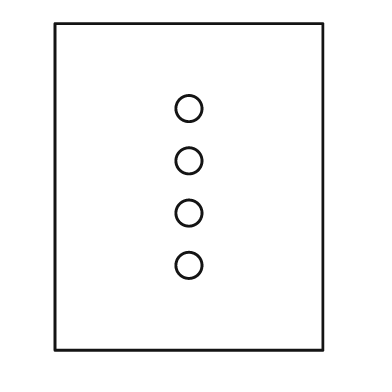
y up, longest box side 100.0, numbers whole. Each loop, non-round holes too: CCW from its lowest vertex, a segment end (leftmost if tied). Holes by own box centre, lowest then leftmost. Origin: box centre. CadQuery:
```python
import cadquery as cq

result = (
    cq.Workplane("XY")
    .moveTo(-41.0, -50.0)
    .lineTo(41.0, -50.0)
    .lineTo(41.0, 50.0)
    .lineTo(-41.0, 50.0)
    .close()
    .moveTo(0.0, -24.0)
    .circle(4.0)
    .moveTo(0.0, -8.0)
    .circle(4.0)
    .moveTo(0.0, 8.0)
    .circle(4.0)
    .moveTo(0.0, 24.0)
    .circle(4.0)
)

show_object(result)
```